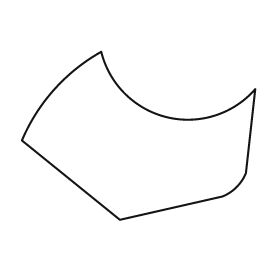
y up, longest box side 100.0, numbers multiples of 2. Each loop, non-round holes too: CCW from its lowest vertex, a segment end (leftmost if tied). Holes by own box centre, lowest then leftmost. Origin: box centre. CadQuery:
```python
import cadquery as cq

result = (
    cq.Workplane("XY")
    .moveTo(-8.0, -36.0)
    .lineTo(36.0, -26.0)
    .threePointArc((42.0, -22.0), (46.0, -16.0))
    .lineTo(50.0, 20.0)
    .threePointArc((12.0, 8.0), (-16.0, 36.0))
    .threePointArc((-36.0, 20.0), (-50.0, -2.0))
    .close()
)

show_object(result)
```